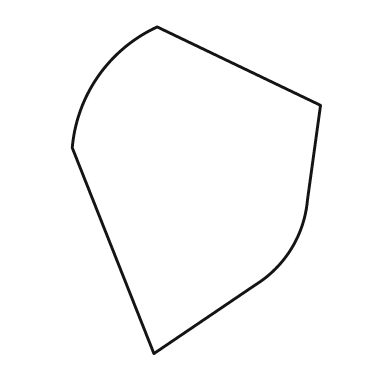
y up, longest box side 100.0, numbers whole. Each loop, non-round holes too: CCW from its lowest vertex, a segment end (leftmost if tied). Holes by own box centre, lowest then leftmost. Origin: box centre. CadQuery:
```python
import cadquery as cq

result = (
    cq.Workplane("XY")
    .moveTo(-13.0, -50.0)
    .lineTo(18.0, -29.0)
    .threePointArc((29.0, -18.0), (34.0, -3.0))
    .lineTo(38.0, 26.0)
    .lineTo(-12.0, 50.0)
    .threePointArc((-30.0, 35.0), (-38.0, 13.0))
    .close()
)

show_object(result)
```